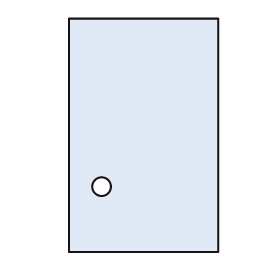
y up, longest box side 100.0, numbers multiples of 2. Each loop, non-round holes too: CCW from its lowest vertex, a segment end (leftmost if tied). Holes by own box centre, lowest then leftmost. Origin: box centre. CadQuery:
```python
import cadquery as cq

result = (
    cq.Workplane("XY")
    .moveTo(-32.0, -50.0)
    .lineTo(32.0, -50.0)
    .lineTo(32.0, 50.0)
    .lineTo(-32.0, 50.0)
    .close()
    .moveTo(-18.0, -22.0)
    .circle(4.0)
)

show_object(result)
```